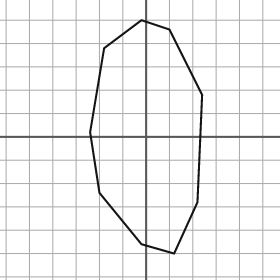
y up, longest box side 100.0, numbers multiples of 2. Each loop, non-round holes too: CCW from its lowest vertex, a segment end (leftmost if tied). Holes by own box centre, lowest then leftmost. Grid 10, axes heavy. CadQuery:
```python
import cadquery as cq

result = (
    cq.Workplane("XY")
    .moveTo(12.0, -50.0)
    .lineTo(22.0, -28.0)
    .lineTo(24.0, 18.0)
    .lineTo(10.0, 46.0)
    .lineTo(-2.0, 50.0)
    .lineTo(-18.0, 38.0)
    .lineTo(-24.0, 2.0)
    .lineTo(-20.0, -24.0)
    .lineTo(-2.0, -46.0)
    .close()
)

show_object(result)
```